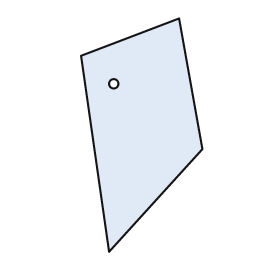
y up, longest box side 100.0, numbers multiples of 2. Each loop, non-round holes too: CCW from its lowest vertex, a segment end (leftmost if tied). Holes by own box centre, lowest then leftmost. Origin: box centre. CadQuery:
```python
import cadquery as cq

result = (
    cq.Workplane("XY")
    .moveTo(-14.0, -50.0)
    .lineTo(26.0, -6.0)
    .lineTo(16.0, 50.0)
    .lineTo(-26.0, 34.0)
    .close()
    .moveTo(-12.0, 22.0)
    .circle(2.0)
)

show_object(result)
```